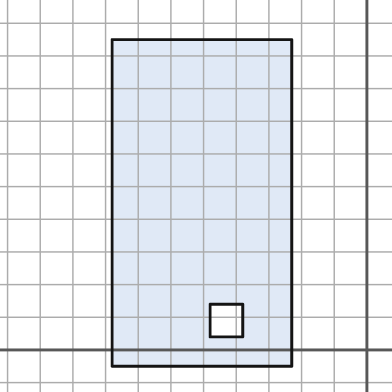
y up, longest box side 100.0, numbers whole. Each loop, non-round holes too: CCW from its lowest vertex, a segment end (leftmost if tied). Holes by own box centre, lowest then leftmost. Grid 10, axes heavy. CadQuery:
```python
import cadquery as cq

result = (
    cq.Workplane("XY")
    .moveTo(-78.0, -5.0)
    .lineTo(-23.0, -5.0)
    .lineTo(-23.0, 95.0)
    .lineTo(-78.0, 95.0)
    .close()
    .moveTo(-48.0, 4.0)
    .lineTo(-38.0, 4.0)
    .lineTo(-38.0, 14.0)
    .lineTo(-48.0, 14.0)
    .close()
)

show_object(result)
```